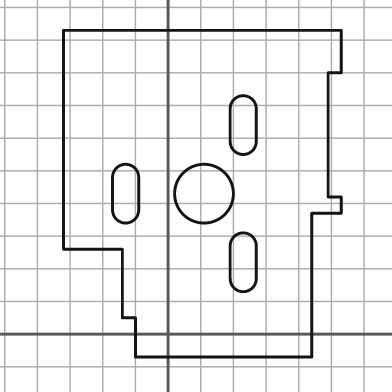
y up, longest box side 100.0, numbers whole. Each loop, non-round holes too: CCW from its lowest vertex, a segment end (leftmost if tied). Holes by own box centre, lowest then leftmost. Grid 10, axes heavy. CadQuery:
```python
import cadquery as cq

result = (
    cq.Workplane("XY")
    .moveTo(-10.0, -7.0)
    .lineTo(44.0, -7.0)
    .lineTo(44.0, 37.0)
    .lineTo(53.0, 37.0)
    .lineTo(53.0, 42.0)
    .lineTo(49.0, 42.0)
    .lineTo(49.0, 80.0)
    .lineTo(53.0, 80.0)
    .lineTo(53.0, 93.0)
    .lineTo(-32.0, 93.0)
    .lineTo(-32.0, 26.0)
    .lineTo(-14.0, 26.0)
    .lineTo(-14.0, 5.0)
    .lineTo(-10.0, 5.0)
    .close()
    .moveTo(19.0, 17.0)
    .threePointArc((23.0, 13.0), (27.0, 17.0))
    .lineTo(27.0, 27.0)
    .threePointArc((23.0, 31.0), (19.0, 27.0))
    .close()
    .moveTo(-17.0, 38.0)
    .threePointArc((-13.0, 34.0), (-9.0, 38.0))
    .lineTo(-9.0, 48.0)
    .threePointArc((-13.0, 52.0), (-17.0, 48.0))
    .close()
    .moveTo(11.0, 43.0)
    .circle(9.0)
    .moveTo(19.0, 59.0)
    .threePointArc((23.0, 55.0), (27.0, 59.0))
    .lineTo(27.0, 69.0)
    .threePointArc((23.0, 73.0), (19.0, 69.0))
    .close()
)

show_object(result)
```